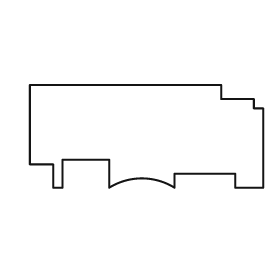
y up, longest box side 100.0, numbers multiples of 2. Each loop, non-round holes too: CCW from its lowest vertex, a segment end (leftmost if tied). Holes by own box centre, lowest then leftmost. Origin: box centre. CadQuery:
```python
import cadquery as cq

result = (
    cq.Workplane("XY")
    .moveTo(-40.0, -22.0)
    .lineTo(-36.0, -22.0)
    .lineTo(-36.0, -10.0)
    .lineTo(-16.0, -10.0)
    .lineTo(-16.0, -22.0)
    .threePointArc((-2.0, -18.0), (12.0, -22.0))
    .lineTo(12.0, -16.0)
    .lineTo(38.0, -16.0)
    .lineTo(38.0, -22.0)
    .lineTo(50.0, -22.0)
    .lineTo(50.0, 12.0)
    .lineTo(46.0, 12.0)
    .lineTo(46.0, 16.0)
    .lineTo(32.0, 16.0)
    .lineTo(32.0, 22.0)
    .lineTo(-50.0, 22.0)
    .lineTo(-50.0, -12.0)
    .lineTo(-40.0, -12.0)
    .close()
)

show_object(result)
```